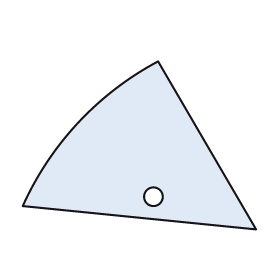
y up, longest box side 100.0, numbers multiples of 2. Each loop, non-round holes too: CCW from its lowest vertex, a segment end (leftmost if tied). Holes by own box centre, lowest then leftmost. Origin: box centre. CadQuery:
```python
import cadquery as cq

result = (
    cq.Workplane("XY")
    .moveTo(50.0, -36.0)
    .lineTo(8.0, 36.0)
    .threePointArc((-26.0, 10.0), (-50.0, -26.0))
    .close()
    .moveTo(6.0, -22.0)
    .circle(4.0)
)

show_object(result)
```